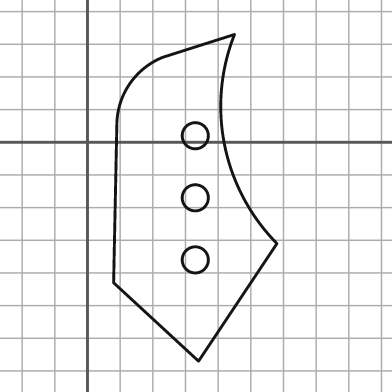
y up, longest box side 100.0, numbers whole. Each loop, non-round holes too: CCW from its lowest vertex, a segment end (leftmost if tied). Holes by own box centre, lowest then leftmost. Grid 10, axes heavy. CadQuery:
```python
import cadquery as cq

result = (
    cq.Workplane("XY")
    .moveTo(34.0, -67.0)
    .lineTo(58.0, -31.0)
    .threePointArc((42.0, -1.0), (45.0, 33.0))
    .lineTo(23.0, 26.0)
    .threePointArc((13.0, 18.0), (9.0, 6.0))
    .lineTo(8.0, -43.0)
    .close()
    .moveTo(33.0, -36.0)
    .circle(4.0)
    .moveTo(33.0, -17.0)
    .circle(4.0)
    .moveTo(33.0, 2.0)
    .circle(4.0)
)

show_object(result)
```